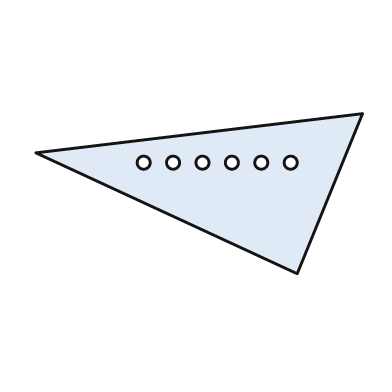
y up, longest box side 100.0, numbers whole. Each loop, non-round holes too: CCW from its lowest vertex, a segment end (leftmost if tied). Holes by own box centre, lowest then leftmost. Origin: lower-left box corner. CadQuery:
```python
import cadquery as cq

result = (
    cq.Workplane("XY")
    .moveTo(80.0, 0.0)
    .lineTo(100.0, 49.0)
    .lineTo(0.0, 37.0)
    .close()
    .moveTo(33.0, 34.0)
    .circle(2.0)
    .moveTo(42.0, 34.0)
    .circle(2.0)
    .moveTo(51.0, 34.0)
    .circle(2.0)
    .moveTo(60.0, 34.0)
    .circle(2.0)
    .moveTo(69.0, 34.0)
    .circle(2.0)
    .moveTo(78.0, 34.0)
    .circle(2.0)
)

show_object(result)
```